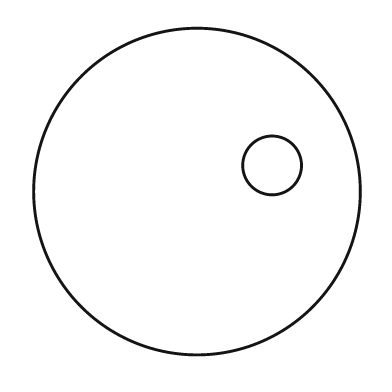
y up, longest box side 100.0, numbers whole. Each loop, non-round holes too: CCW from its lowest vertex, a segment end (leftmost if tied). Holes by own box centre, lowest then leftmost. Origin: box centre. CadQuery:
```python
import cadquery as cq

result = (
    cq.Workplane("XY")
    .moveTo(0.0, 0.0)
    .circle(50.0)
    .moveTo(23.0, 8.0)
    .circle(9.0)
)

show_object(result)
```